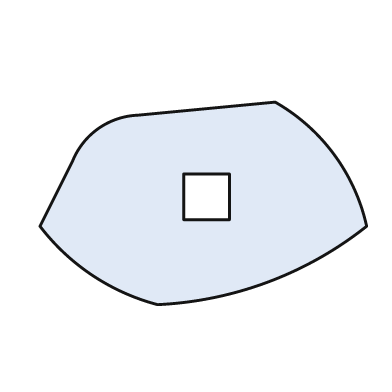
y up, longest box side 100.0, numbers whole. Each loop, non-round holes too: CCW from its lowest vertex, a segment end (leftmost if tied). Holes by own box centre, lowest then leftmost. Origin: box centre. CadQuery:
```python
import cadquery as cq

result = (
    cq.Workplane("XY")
    .moveTo(-14.0, -31.0)
    .threePointArc((20.0, -24.0), (50.0, -7.0))
    .threePointArc((40.0, 15.0), (22.0, 31.0))
    .lineTo(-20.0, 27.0)
    .threePointArc((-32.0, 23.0), (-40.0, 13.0))
    .lineTo(-50.0, -7.0)
    .threePointArc((-34.0, -22.0), (-14.0, -31.0))
    .close()
    .moveTo(-6.0, -5.0)
    .lineTo(8.0, -5.0)
    .lineTo(8.0, 9.0)
    .lineTo(-6.0, 9.0)
    .close()
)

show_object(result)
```